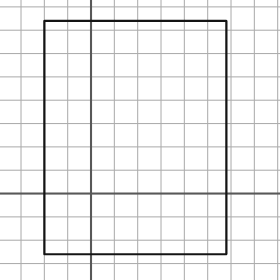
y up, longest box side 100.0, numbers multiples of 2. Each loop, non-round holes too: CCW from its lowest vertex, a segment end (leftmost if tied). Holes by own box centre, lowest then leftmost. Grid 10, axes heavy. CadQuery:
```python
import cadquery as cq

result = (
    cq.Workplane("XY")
    .moveTo(-20.0, -26.0)
    .lineTo(58.0, -26.0)
    .lineTo(58.0, 74.0)
    .lineTo(-20.0, 74.0)
    .close()
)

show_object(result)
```